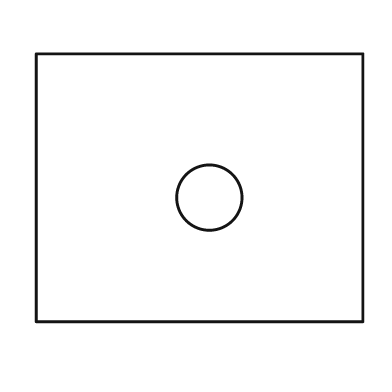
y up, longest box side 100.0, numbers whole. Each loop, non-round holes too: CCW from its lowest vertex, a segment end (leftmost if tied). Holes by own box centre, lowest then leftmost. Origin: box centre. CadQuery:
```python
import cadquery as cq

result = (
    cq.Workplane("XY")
    .moveTo(-50.0, -41.0)
    .lineTo(50.0, -41.0)
    .lineTo(50.0, 41.0)
    .lineTo(-50.0, 41.0)
    .close()
    .moveTo(3.0, -3.0)
    .circle(10.0)
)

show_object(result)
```